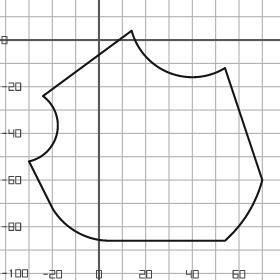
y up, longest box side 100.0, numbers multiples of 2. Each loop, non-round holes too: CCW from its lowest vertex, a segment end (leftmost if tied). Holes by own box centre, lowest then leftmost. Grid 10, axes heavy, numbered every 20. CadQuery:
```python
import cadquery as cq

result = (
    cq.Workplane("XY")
    .moveTo(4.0, -86.0)
    .lineTo(54.0, -86.0)
    .threePointArc((64.0, -74.0), (70.0, -60.0))
    .lineTo(54.0, -12.0)
    .threePointArc((30.0, -14.0), (14.0, 4.0))
    .lineTo(-24.0, -24.0)
    .threePointArc((-18.0, -40.0), (-30.0, -52.0))
    .lineTo(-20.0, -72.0)
    .threePointArc((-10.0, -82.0), (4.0, -86.0))
    .close()
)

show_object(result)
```